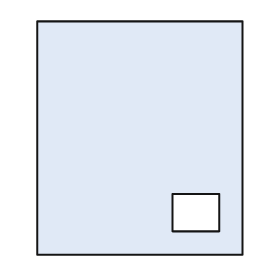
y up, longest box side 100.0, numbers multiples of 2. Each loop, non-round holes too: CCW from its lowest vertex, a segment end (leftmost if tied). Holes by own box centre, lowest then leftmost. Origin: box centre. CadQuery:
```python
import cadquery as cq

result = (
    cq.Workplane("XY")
    .moveTo(-44.0, -50.0)
    .lineTo(44.0, -50.0)
    .lineTo(44.0, 50.0)
    .lineTo(-44.0, 50.0)
    .close()
    .moveTo(14.0, -40.0)
    .lineTo(34.0, -40.0)
    .lineTo(34.0, -24.0)
    .lineTo(14.0, -24.0)
    .close()
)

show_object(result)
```